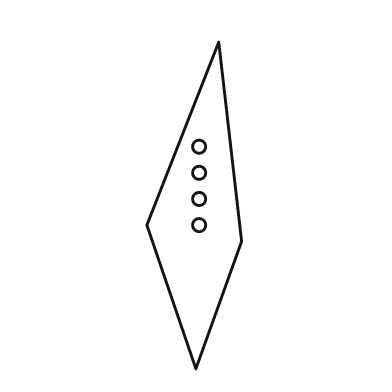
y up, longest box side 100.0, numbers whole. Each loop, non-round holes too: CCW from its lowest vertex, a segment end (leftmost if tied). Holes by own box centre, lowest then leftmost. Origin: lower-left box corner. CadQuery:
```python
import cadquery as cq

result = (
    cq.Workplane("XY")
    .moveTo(15.0, 0.0)
    .lineTo(29.0, 39.0)
    .lineTo(22.0, 100.0)
    .lineTo(0.0, 44.0)
    .close()
    .moveTo(16.0, 44.0)
    .circle(2.0)
    .moveTo(16.0, 52.0)
    .circle(2.0)
    .moveTo(16.0, 60.0)
    .circle(2.0)
    .moveTo(16.0, 68.0)
    .circle(2.0)
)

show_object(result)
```